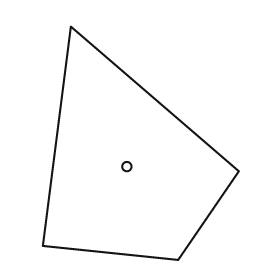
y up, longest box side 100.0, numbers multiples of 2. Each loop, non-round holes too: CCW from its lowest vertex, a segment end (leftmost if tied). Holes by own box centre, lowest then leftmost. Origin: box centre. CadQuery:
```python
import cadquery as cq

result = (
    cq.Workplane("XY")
    .moveTo(16.0, -50.0)
    .lineTo(42.0, -12.0)
    .lineTo(-30.0, 50.0)
    .lineTo(-42.0, -44.0)
    .close()
    .moveTo(-6.0, -10.0)
    .circle(2.0)
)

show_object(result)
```